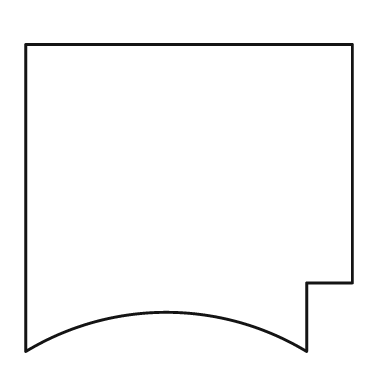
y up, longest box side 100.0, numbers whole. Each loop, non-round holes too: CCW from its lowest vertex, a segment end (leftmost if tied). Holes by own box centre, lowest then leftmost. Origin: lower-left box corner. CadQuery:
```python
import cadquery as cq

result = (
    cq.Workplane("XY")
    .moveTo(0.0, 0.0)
    .threePointArc((43.0, 12.0), (86.0, 0.0))
    .lineTo(86.0, 21.0)
    .lineTo(100.0, 21.0)
    .lineTo(100.0, 94.0)
    .lineTo(0.0, 94.0)
    .close()
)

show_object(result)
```